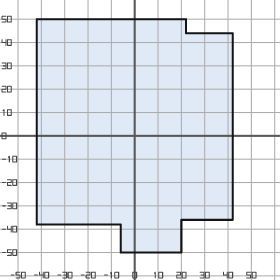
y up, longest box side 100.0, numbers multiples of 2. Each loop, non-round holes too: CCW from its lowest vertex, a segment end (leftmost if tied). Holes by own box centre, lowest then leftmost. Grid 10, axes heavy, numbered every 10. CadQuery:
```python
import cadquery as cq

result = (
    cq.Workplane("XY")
    .moveTo(-6.0, -50.0)
    .lineTo(20.0, -50.0)
    .lineTo(20.0, -36.0)
    .lineTo(42.0, -36.0)
    .lineTo(42.0, 44.0)
    .lineTo(22.0, 44.0)
    .lineTo(22.0, 50.0)
    .lineTo(-42.0, 50.0)
    .lineTo(-42.0, -38.0)
    .lineTo(-6.0, -38.0)
    .close()
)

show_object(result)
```